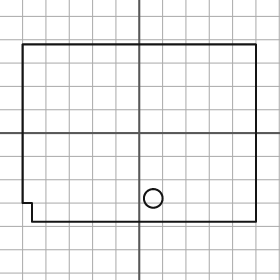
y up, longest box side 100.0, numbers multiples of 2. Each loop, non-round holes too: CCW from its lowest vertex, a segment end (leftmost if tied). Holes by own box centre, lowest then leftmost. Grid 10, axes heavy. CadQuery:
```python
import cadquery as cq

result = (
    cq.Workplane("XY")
    .moveTo(-46.0, -38.0)
    .lineTo(50.0, -38.0)
    .lineTo(50.0, 38.0)
    .lineTo(-50.0, 38.0)
    .lineTo(-50.0, -30.0)
    .lineTo(-46.0, -30.0)
    .close()
    .moveTo(6.0, -28.0)
    .circle(4.0)
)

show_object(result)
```